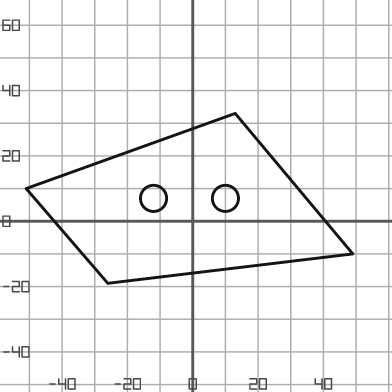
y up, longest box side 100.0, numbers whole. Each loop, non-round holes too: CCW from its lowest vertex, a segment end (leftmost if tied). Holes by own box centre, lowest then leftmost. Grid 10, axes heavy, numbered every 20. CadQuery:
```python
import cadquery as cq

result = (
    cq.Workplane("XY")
    .moveTo(-26.0, -19.0)
    .lineTo(49.0, -10.0)
    .lineTo(13.0, 33.0)
    .lineTo(-51.0, 10.0)
    .close()
    .moveTo(-12.0, 7.0)
    .circle(4.0)
    .moveTo(10.0, 7.0)
    .circle(4.0)
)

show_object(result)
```